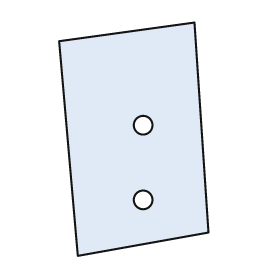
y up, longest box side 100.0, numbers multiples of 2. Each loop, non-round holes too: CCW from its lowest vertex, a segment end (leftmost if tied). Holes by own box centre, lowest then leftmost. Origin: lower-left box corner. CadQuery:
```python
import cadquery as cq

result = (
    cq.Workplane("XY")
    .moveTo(8.0, 0.0)
    .lineTo(64.0, 10.0)
    .lineTo(58.0, 100.0)
    .lineTo(0.0, 92.0)
    .close()
    .moveTo(36.0, 24.0)
    .circle(4.0)
    .moveTo(36.0, 56.0)
    .circle(4.0)
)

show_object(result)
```